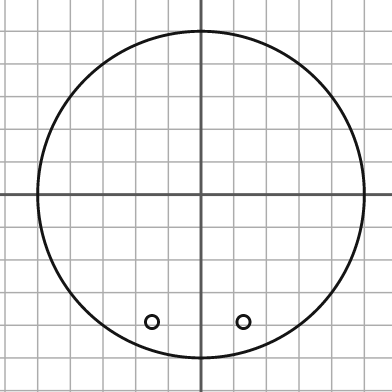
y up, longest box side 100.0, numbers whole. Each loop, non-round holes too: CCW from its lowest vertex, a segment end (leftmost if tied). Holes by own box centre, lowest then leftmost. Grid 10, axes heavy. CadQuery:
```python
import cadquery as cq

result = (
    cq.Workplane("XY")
    .moveTo(0.0, 0.0)
    .circle(50.0)
    .moveTo(-15.0, -39.0)
    .circle(2.0)
    .moveTo(13.0, -39.0)
    .circle(2.0)
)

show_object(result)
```